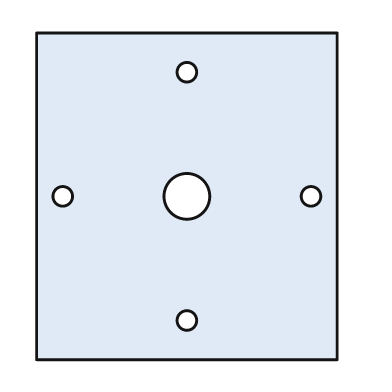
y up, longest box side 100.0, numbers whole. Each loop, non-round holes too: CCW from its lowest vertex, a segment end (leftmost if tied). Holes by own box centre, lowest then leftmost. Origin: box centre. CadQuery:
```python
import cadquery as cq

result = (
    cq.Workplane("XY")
    .moveTo(-46.0, -50.0)
    .lineTo(46.0, -50.0)
    .lineTo(46.0, 50.0)
    .lineTo(-46.0, 50.0)
    .close()
    .moveTo(0.0, -38.0)
    .circle(3.0)
    .moveTo(-38.0, 0.0)
    .circle(3.0)
    .moveTo(0.0, 0.0)
    .circle(7.0)
    .moveTo(38.0, 0.0)
    .circle(3.0)
    .moveTo(0.0, 38.0)
    .circle(3.0)
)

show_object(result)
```